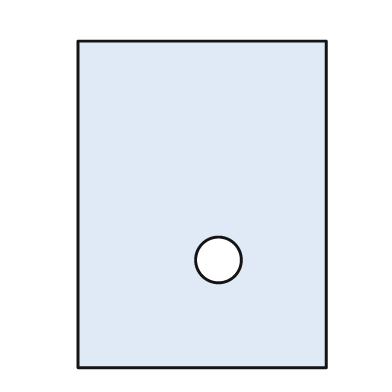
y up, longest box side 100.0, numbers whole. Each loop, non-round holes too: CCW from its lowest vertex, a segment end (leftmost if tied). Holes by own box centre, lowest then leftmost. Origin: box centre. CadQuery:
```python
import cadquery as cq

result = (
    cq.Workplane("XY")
    .moveTo(-38.0, -50.0)
    .lineTo(38.0, -50.0)
    .lineTo(38.0, 50.0)
    .lineTo(-38.0, 50.0)
    .close()
    .moveTo(5.0, -17.0)
    .circle(7.0)
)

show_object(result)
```